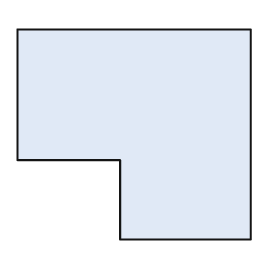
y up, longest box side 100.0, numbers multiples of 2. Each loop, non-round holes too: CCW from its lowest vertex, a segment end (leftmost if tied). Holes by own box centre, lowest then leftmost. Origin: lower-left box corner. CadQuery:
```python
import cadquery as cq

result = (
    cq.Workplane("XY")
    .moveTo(44.0, 0.0)
    .lineTo(100.0, 0.0)
    .lineTo(100.0, 90.0)
    .lineTo(0.0, 90.0)
    .lineTo(0.0, 34.0)
    .lineTo(44.0, 34.0)
    .close()
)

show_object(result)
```